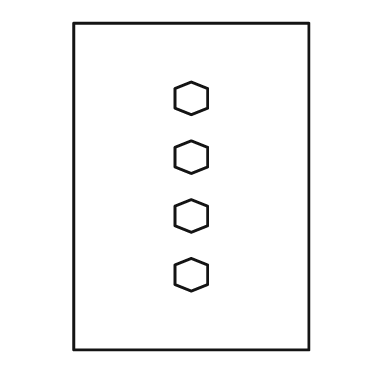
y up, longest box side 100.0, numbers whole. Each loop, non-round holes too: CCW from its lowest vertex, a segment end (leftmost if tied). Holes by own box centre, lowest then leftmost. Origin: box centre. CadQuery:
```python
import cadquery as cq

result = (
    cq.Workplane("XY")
    .moveTo(-36.0, -50.0)
    .lineTo(36.0, -50.0)
    .lineTo(36.0, 50.0)
    .lineTo(-36.0, 50.0)
    .close()
    .moveTo(0.0, -32.0)
    .lineTo(5.0, -30.0)
    .lineTo(5.0, -24.0)
    .lineTo(0.0, -22.0)
    .lineTo(-5.0, -24.0)
    .lineTo(-5.0, -30.0)
    .close()
    .moveTo(0.0, -14.0)
    .lineTo(5.0, -12.0)
    .lineTo(5.0, -6.0)
    .lineTo(0.0, -4.0)
    .lineTo(-5.0, -6.0)
    .lineTo(-5.0, -12.0)
    .close()
    .moveTo(0.0, 4.0)
    .lineTo(5.0, 6.0)
    .lineTo(5.0, 12.0)
    .lineTo(0.0, 14.0)
    .lineTo(-5.0, 12.0)
    .lineTo(-5.0, 6.0)
    .close()
    .moveTo(0.0, 22.0)
    .lineTo(5.0, 24.0)
    .lineTo(5.0, 30.0)
    .lineTo(0.0, 32.0)
    .lineTo(-5.0, 30.0)
    .lineTo(-5.0, 24.0)
    .close()
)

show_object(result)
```